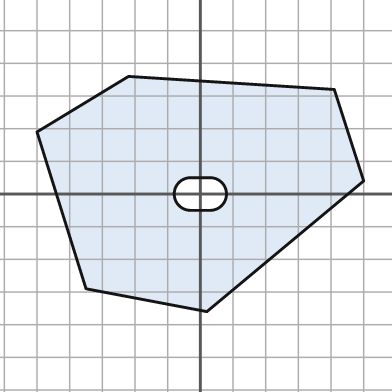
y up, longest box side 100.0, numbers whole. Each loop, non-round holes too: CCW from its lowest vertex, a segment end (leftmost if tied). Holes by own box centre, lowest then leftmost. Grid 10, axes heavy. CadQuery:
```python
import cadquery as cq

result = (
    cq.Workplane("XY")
    .moveTo(2.0, -36.0)
    .lineTo(50.0, 4.0)
    .lineTo(41.0, 32.0)
    .lineTo(-22.0, 36.0)
    .lineTo(-50.0, 19.0)
    .lineTo(-35.0, -29.0)
    .close()
    .moveTo(-3.0, -5.0)
    .lineTo(3.0, -5.0)
    .threePointArc((8.0, 0.0), (3.0, 5.0))
    .lineTo(-3.0, 5.0)
    .threePointArc((-8.0, 0.0), (-3.0, -5.0))
    .close()
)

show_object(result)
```